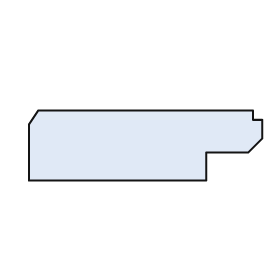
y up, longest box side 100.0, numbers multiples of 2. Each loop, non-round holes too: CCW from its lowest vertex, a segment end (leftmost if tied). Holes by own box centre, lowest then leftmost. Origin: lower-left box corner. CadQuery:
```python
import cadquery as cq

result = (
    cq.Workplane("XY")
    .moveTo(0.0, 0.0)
    .lineTo(76.0, 0.0)
    .lineTo(76.0, 12.0)
    .lineTo(94.0, 12.0)
    .lineTo(100.0, 18.0)
    .lineTo(100.0, 26.0)
    .lineTo(96.0, 26.0)
    .lineTo(96.0, 30.0)
    .lineTo(4.0, 30.0)
    .lineTo(0.0, 24.0)
    .close()
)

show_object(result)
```